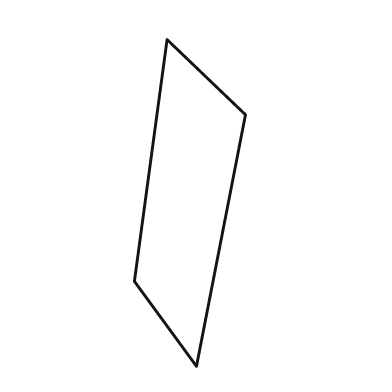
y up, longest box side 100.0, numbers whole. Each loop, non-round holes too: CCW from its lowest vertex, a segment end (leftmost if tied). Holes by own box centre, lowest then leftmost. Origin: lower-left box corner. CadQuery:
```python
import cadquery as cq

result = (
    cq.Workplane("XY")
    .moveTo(19.0, 0.0)
    .lineTo(34.0, 77.0)
    .lineTo(10.0, 100.0)
    .lineTo(0.0, 26.0)
    .close()
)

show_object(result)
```